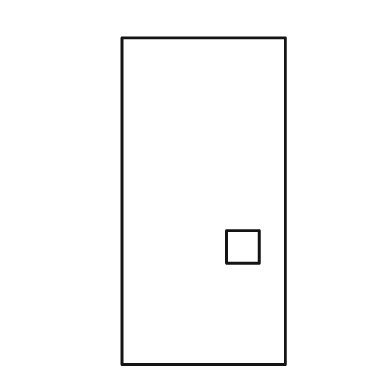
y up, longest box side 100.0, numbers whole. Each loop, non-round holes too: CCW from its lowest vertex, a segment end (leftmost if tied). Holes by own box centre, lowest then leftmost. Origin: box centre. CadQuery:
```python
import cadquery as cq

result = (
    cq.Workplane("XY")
    .moveTo(-25.0, -50.0)
    .lineTo(25.0, -50.0)
    .lineTo(25.0, 50.0)
    .lineTo(-25.0, 50.0)
    .close()
    .moveTo(7.0, -19.0)
    .lineTo(17.0, -19.0)
    .lineTo(17.0, -9.0)
    .lineTo(7.0, -9.0)
    .close()
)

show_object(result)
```